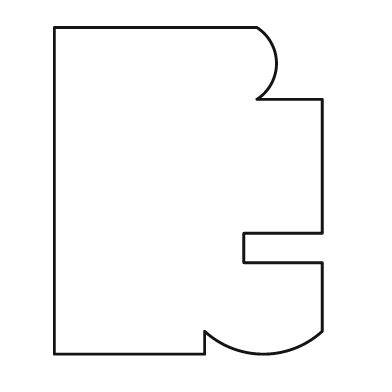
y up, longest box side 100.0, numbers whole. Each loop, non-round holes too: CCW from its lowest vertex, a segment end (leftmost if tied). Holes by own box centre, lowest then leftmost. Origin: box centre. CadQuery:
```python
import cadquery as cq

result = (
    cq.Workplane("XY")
    .moveTo(-41.0, -50.0)
    .lineTo(5.0, -50.0)
    .lineTo(5.0, -43.0)
    .threePointArc((23.0, -50.0), (41.0, -43.0))
    .lineTo(41.0, -22.0)
    .lineTo(17.0, -22.0)
    .lineTo(17.0, -13.0)
    .lineTo(41.0, -13.0)
    .lineTo(41.0, 28.0)
    .lineTo(21.0, 28.0)
    .threePointArc((27.0, 39.0), (21.0, 50.0))
    .lineTo(-41.0, 50.0)
    .close()
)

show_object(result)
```